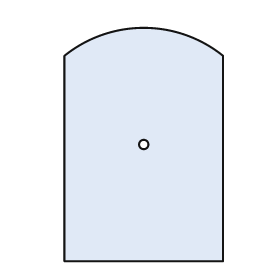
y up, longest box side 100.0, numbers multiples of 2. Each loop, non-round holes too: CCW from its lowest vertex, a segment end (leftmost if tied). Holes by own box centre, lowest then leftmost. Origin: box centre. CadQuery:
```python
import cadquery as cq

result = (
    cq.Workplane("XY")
    .moveTo(-34.0, -50.0)
    .lineTo(34.0, -50.0)
    .lineTo(34.0, 38.0)
    .threePointArc((0.0, 50.0), (-34.0, 38.0))
    .close()
    .moveTo(0.0, 0.0)
    .circle(2.0)
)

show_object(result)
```